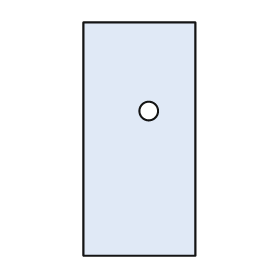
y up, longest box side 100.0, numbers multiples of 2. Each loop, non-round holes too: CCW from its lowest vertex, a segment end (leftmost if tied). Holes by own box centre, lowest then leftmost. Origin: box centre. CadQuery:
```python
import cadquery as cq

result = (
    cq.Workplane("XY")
    .moveTo(-24.0, -50.0)
    .lineTo(24.0, -50.0)
    .lineTo(24.0, 50.0)
    .lineTo(-24.0, 50.0)
    .close()
    .moveTo(4.0, 12.0)
    .circle(4.0)
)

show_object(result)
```